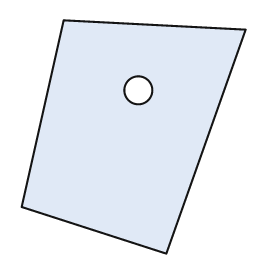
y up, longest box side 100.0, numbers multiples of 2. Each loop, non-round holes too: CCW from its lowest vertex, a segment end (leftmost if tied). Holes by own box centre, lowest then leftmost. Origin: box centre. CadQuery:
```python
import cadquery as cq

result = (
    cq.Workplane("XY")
    .moveTo(14.0, -50.0)
    .lineTo(48.0, 46.0)
    .lineTo(-30.0, 50.0)
    .lineTo(-48.0, -30.0)
    .close()
    .moveTo(2.0, 20.0)
    .circle(6.0)
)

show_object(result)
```